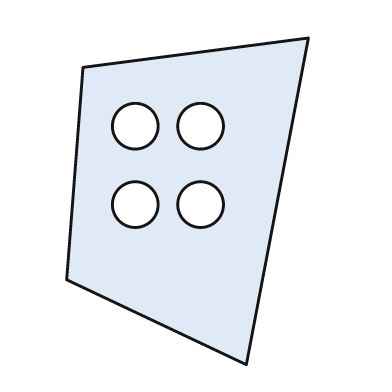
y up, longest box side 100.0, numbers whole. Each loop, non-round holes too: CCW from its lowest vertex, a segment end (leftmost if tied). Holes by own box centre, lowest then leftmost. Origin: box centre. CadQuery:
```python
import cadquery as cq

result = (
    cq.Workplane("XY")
    .moveTo(18.0, -50.0)
    .lineTo(37.0, 50.0)
    .lineTo(-32.0, 41.0)
    .lineTo(-37.0, -24.0)
    .close()
    .moveTo(-16.0, -1.0)
    .circle(7.0)
    .moveTo(4.0, -1.0)
    .circle(7.0)
    .moveTo(-16.0, 23.0)
    .circle(7.0)
    .moveTo(4.0, 23.0)
    .circle(7.0)
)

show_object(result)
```